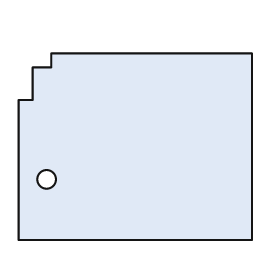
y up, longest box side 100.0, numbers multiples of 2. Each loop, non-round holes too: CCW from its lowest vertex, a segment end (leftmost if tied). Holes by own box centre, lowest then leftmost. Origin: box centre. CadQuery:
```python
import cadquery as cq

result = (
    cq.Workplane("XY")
    .moveTo(-50.0, -40.0)
    .lineTo(50.0, -40.0)
    .lineTo(50.0, 40.0)
    .lineTo(-36.0, 40.0)
    .lineTo(-36.0, 34.0)
    .lineTo(-44.0, 34.0)
    .lineTo(-44.0, 20.0)
    .lineTo(-50.0, 20.0)
    .close()
    .moveTo(-38.0, -14.0)
    .circle(4.0)
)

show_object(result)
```